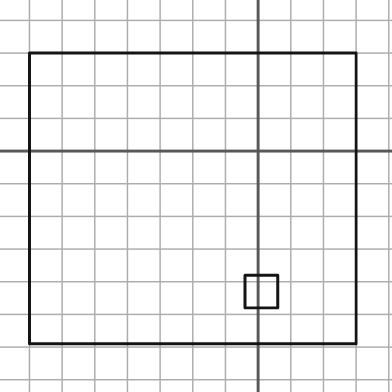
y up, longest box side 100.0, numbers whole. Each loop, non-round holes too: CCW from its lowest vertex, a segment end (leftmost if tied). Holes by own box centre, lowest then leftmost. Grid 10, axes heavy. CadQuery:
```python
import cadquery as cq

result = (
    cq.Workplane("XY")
    .moveTo(-70.0, -59.0)
    .lineTo(30.0, -59.0)
    .lineTo(30.0, 30.0)
    .lineTo(-70.0, 30.0)
    .close()
    .moveTo(-4.0, -48.0)
    .lineTo(6.0, -48.0)
    .lineTo(6.0, -38.0)
    .lineTo(-4.0, -38.0)
    .close()
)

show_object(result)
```